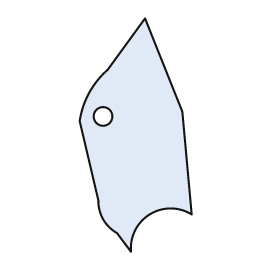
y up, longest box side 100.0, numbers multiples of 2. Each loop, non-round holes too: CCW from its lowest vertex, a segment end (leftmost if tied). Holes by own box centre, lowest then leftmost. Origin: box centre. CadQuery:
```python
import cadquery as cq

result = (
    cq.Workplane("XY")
    .moveTo(-2.0, -50.0)
    .threePointArc((6.0, -34.0), (24.0, -34.0))
    .lineTo(20.0, 10.0)
    .lineTo(4.0, 50.0)
    .lineTo(-12.0, 28.0)
    .threePointArc((-20.0, 18.0), (-24.0, 6.0))
    .lineTo(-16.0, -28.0)
    .threePointArc((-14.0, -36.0), (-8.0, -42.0))
    .close()
    .moveTo(-14.0, 8.0)
    .circle(4.0)
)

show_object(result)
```